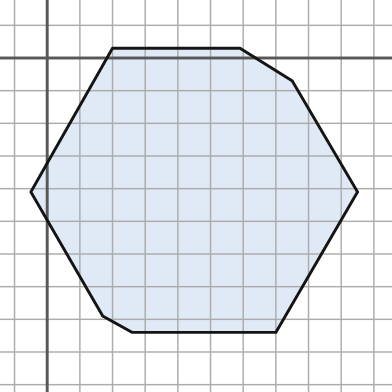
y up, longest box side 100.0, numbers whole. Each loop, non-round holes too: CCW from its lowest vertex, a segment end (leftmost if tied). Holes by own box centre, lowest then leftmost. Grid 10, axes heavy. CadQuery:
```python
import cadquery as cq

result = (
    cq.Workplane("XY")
    .moveTo(26.0, -84.0)
    .lineTo(70.0, -84.0)
    .lineTo(95.0, -41.0)
    .lineTo(75.0, -7.0)
    .lineTo(59.0, 3.0)
    .lineTo(20.0, 3.0)
    .lineTo(-5.0, -41.0)
    .lineTo(17.0, -79.0)
    .close()
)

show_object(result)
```